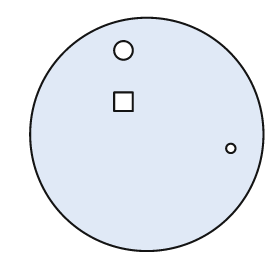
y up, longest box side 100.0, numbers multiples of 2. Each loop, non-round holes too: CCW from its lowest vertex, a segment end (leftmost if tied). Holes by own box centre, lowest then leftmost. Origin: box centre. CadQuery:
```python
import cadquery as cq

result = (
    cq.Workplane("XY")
    .moveTo(0.0, 0.0)
    .circle(50.0)
    .moveTo(36.0, -6.0)
    .circle(2.0)
    .moveTo(-14.0, 10.0)
    .lineTo(-6.0, 10.0)
    .lineTo(-6.0, 18.0)
    .lineTo(-14.0, 18.0)
    .close()
    .moveTo(-10.0, 36.0)
    .circle(4.0)
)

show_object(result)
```